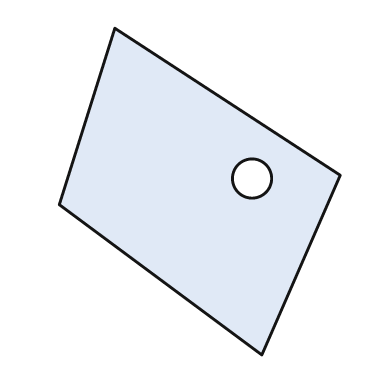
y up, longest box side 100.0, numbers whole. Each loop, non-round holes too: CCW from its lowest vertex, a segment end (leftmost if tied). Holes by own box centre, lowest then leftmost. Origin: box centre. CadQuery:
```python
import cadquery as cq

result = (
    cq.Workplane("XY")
    .moveTo(19.0, -50.0)
    .lineTo(43.0, 5.0)
    .lineTo(-26.0, 50.0)
    .lineTo(-43.0, -4.0)
    .close()
    .moveTo(16.0, 4.0)
    .circle(6.0)
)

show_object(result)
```